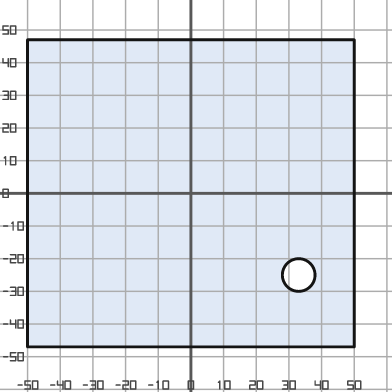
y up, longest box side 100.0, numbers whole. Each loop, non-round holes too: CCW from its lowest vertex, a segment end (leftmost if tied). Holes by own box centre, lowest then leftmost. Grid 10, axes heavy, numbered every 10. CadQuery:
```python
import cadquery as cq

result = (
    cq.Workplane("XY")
    .moveTo(-50.0, -47.0)
    .lineTo(50.0, -47.0)
    .lineTo(50.0, 47.0)
    .lineTo(-50.0, 47.0)
    .close()
    .moveTo(33.0, -25.0)
    .circle(5.0)
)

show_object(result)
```